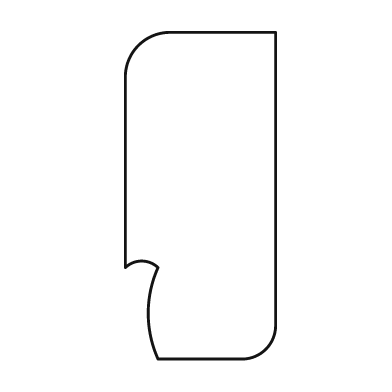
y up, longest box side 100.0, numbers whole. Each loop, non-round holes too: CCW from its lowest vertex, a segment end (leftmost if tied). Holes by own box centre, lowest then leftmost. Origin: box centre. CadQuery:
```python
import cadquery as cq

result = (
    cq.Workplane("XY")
    .moveTo(-13.0, -50.0)
    .lineTo(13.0, -50.0)
    .threePointArc((20.0, -47.0), (23.0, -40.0))
    .lineTo(23.0, 50.0)
    .lineTo(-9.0, 50.0)
    .threePointArc((-19.0, 46.0), (-23.0, 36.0))
    .lineTo(-23.0, -22.0)
    .threePointArc((-18.0, -20.0), (-13.0, -22.0))
    .threePointArc((-16.0, -36.0), (-13.0, -50.0))
    .close()
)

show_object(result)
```